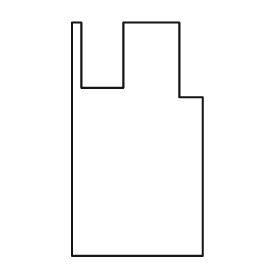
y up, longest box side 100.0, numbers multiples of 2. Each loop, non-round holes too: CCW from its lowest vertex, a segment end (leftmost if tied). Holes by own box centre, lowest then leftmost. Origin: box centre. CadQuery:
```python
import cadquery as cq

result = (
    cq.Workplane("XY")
    .moveTo(-28.0, -50.0)
    .lineTo(28.0, -50.0)
    .lineTo(28.0, 18.0)
    .lineTo(18.0, 18.0)
    .lineTo(18.0, 50.0)
    .lineTo(-6.0, 50.0)
    .lineTo(-6.0, 22.0)
    .lineTo(-24.0, 22.0)
    .lineTo(-24.0, 50.0)
    .lineTo(-28.0, 50.0)
    .close()
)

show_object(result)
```